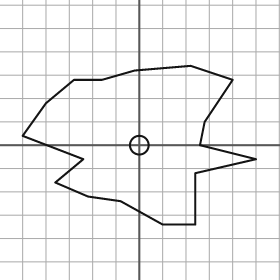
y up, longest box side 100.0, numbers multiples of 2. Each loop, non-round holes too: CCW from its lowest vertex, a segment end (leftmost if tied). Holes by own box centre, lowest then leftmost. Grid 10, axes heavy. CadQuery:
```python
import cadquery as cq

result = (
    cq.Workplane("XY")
    .moveTo(10.0, -34.0)
    .lineTo(24.0, -34.0)
    .lineTo(24.0, -12.0)
    .lineTo(50.0, -6.0)
    .lineTo(26.0, 0.0)
    .lineTo(28.0, 10.0)
    .lineTo(40.0, 28.0)
    .lineTo(22.0, 34.0)
    .lineTo(-2.0, 32.0)
    .lineTo(-16.0, 28.0)
    .lineTo(-28.0, 28.0)
    .lineTo(-40.0, 18.0)
    .lineTo(-50.0, 4.0)
    .lineTo(-24.0, -6.0)
    .lineTo(-36.0, -16.0)
    .lineTo(-22.0, -22.0)
    .lineTo(-8.0, -24.0)
    .close()
    .moveTo(0.0, 0.0)
    .circle(4.0)
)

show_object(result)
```